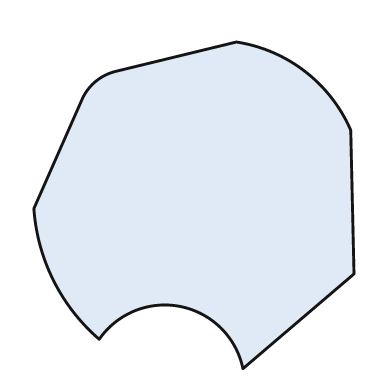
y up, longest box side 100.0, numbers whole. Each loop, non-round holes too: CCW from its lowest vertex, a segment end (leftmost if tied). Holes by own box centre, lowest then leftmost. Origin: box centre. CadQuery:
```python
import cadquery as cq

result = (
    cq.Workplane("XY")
    .moveTo(15.0, -50.0)
    .lineTo(49.0, -21.0)
    .lineTo(48.0, 23.0)
    .threePointArc((34.0, 41.0), (13.0, 50.0))
    .lineTo(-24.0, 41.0)
    .threePointArc((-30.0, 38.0), (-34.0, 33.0))
    .lineTo(-49.0, -1.0)
    .threePointArc((-43.0, -23.0), (-29.0, -41.0))
    .threePointArc((-4.0, -31.0), (15.0, -50.0))
    .close()
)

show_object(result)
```